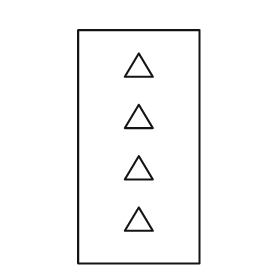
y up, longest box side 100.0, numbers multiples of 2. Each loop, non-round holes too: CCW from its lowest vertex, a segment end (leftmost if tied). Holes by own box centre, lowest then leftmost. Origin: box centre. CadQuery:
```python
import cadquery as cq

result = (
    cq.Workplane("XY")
    .moveTo(-26.0, -50.0)
    .lineTo(26.0, -50.0)
    .lineTo(26.0, 50.0)
    .lineTo(-26.0, 50.0)
    .close()
    .moveTo(-6.0, -36.0)
    .lineTo(6.0, -36.0)
    .lineTo(0.0, -26.0)
    .close()
    .moveTo(-6.0, -14.0)
    .lineTo(6.0, -14.0)
    .lineTo(0.0, -4.0)
    .close()
    .moveTo(-6.0, 8.0)
    .lineTo(6.0, 8.0)
    .lineTo(0.0, 18.0)
    .close()
    .moveTo(-6.0, 30.0)
    .lineTo(6.0, 30.0)
    .lineTo(0.0, 40.0)
    .close()
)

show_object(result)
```